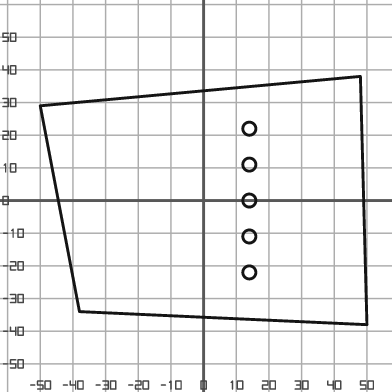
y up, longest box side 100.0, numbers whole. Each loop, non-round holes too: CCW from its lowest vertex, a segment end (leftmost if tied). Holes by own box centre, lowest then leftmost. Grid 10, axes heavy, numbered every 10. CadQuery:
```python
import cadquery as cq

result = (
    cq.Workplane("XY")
    .moveTo(50.0, -38.0)
    .lineTo(48.0, 38.0)
    .lineTo(-50.0, 29.0)
    .lineTo(-38.0, -34.0)
    .close()
    .moveTo(14.0, -22.0)
    .circle(2.0)
    .moveTo(14.0, -11.0)
    .circle(2.0)
    .moveTo(14.0, 0.0)
    .circle(2.0)
    .moveTo(14.0, 11.0)
    .circle(2.0)
    .moveTo(14.0, 22.0)
    .circle(2.0)
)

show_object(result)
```